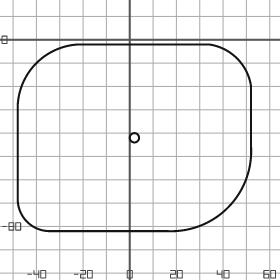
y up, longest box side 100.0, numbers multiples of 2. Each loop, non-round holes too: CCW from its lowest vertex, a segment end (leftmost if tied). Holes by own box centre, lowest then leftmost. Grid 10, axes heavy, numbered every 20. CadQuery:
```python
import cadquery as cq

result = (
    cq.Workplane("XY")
    .moveTo(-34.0, -82.0)
    .lineTo(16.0, -82.0)
    .threePointArc((42.0, -72.0), (52.0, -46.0))
    .lineTo(52.0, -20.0)
    .threePointArc((46.0, -8.0), (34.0, -2.0))
    .lineTo(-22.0, -2.0)
    .threePointArc((-40.0, -10.0), (-48.0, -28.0))
    .lineTo(-48.0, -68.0)
    .threePointArc((-44.0, -78.0), (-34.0, -82.0))
    .close()
    .moveTo(2.0, -42.0)
    .circle(2.0)
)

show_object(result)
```